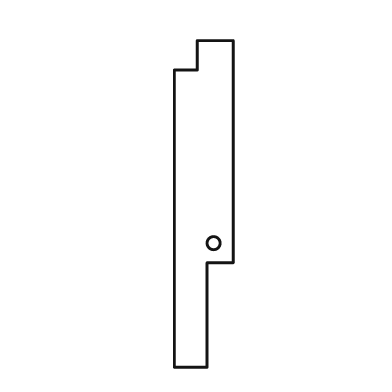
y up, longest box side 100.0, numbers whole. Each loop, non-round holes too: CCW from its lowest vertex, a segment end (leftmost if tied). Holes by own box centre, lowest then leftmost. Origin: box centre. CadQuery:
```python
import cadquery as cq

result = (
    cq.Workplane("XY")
    .moveTo(-9.0, -50.0)
    .lineTo(1.0, -50.0)
    .lineTo(1.0, -18.0)
    .lineTo(9.0, -18.0)
    .lineTo(9.0, 50.0)
    .lineTo(-2.0, 50.0)
    .lineTo(-2.0, 41.0)
    .lineTo(-9.0, 41.0)
    .close()
    .moveTo(3.0, -12.0)
    .circle(2.0)
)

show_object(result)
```